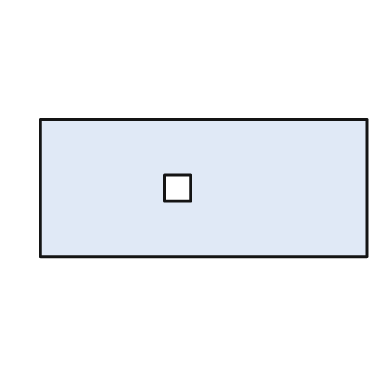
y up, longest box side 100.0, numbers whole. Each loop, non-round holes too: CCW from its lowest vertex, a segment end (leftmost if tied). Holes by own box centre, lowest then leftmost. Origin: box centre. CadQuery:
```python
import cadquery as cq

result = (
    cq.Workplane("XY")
    .moveTo(-50.0, -21.0)
    .lineTo(50.0, -21.0)
    .lineTo(50.0, 21.0)
    .lineTo(-50.0, 21.0)
    .close()
    .moveTo(-12.0, -4.0)
    .lineTo(-4.0, -4.0)
    .lineTo(-4.0, 4.0)
    .lineTo(-12.0, 4.0)
    .close()
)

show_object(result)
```